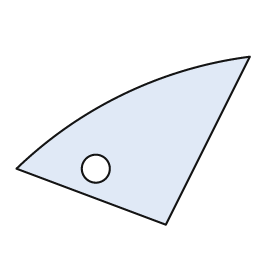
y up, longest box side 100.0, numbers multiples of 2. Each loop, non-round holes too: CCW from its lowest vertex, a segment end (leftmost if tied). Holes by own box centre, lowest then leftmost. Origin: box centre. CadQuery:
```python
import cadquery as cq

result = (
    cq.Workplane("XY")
    .moveTo(14.0, -36.0)
    .lineTo(50.0, 36.0)
    .threePointArc((-4.0, 20.0), (-50.0, -12.0))
    .close()
    .moveTo(-16.0, -12.0)
    .circle(6.0)
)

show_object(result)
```